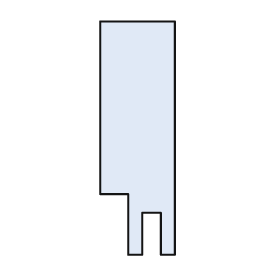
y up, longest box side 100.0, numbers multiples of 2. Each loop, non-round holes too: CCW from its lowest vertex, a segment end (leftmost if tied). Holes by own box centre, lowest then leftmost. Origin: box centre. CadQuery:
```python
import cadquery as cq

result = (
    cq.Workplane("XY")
    .moveTo(-4.0, -50.0)
    .lineTo(2.0, -50.0)
    .lineTo(2.0, -32.0)
    .lineTo(10.0, -32.0)
    .lineTo(10.0, -50.0)
    .lineTo(16.0, -50.0)
    .lineTo(16.0, 50.0)
    .lineTo(-16.0, 50.0)
    .lineTo(-16.0, -24.0)
    .lineTo(-4.0, -24.0)
    .close()
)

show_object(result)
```